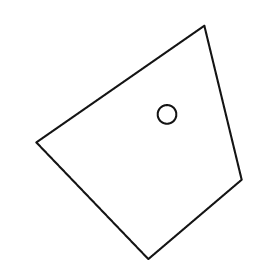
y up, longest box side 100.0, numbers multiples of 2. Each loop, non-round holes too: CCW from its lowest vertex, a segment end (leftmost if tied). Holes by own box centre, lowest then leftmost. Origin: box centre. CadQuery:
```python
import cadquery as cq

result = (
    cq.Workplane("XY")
    .moveTo(4.0, -50.0)
    .lineTo(44.0, -16.0)
    .lineTo(28.0, 50.0)
    .lineTo(-44.0, 0.0)
    .close()
    .moveTo(12.0, 12.0)
    .circle(4.0)
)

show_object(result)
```